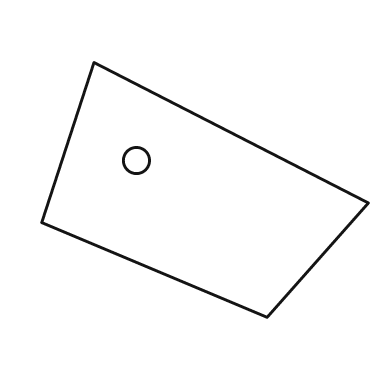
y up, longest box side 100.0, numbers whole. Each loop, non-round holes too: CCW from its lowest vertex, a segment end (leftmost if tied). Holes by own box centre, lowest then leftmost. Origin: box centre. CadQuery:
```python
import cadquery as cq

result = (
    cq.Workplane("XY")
    .moveTo(19.0, -39.0)
    .lineTo(50.0, -4.0)
    .lineTo(-34.0, 39.0)
    .lineTo(-50.0, -10.0)
    .close()
    .moveTo(-21.0, 9.0)
    .circle(4.0)
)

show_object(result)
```